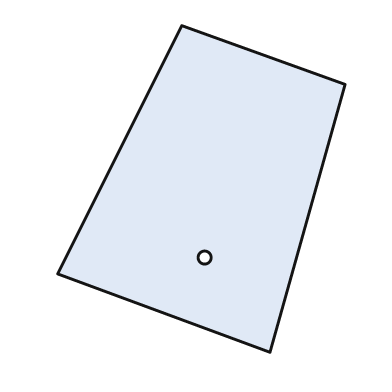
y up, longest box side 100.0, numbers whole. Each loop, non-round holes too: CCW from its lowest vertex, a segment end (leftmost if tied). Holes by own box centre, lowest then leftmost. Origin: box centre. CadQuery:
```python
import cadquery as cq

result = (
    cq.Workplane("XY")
    .moveTo(21.0, -50.0)
    .lineTo(44.0, 32.0)
    .lineTo(-6.0, 50.0)
    .lineTo(-44.0, -26.0)
    .close()
    .moveTo(1.0, -21.0)
    .circle(2.0)
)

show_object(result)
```